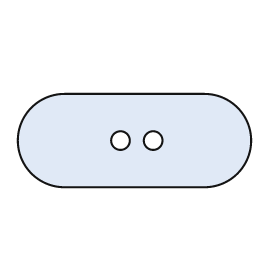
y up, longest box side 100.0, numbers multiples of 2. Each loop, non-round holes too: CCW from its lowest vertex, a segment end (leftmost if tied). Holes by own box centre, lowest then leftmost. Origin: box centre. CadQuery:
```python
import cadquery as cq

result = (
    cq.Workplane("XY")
    .moveTo(-30.0, -20.0)
    .lineTo(30.0, -20.0)
    .threePointArc((50.0, 0.0), (30.0, 20.0))
    .lineTo(-30.0, 20.0)
    .threePointArc((-50.0, 0.0), (-30.0, -20.0))
    .close()
    .moveTo(-6.0, 0.0)
    .circle(4.0)
    .moveTo(8.0, 0.0)
    .circle(4.0)
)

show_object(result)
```